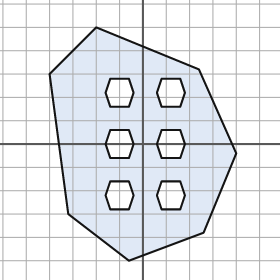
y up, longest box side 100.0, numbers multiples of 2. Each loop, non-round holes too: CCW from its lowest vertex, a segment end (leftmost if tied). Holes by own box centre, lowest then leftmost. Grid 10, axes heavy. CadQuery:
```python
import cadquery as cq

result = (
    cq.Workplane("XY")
    .moveTo(-6.0, -50.0)
    .lineTo(26.0, -38.0)
    .lineTo(40.0, -4.0)
    .lineTo(24.0, 32.0)
    .lineTo(-20.0, 50.0)
    .lineTo(-40.0, 30.0)
    .lineTo(-32.0, -30.0)
    .close()
    .moveTo(-14.0, -28.0)
    .lineTo(-6.0, -28.0)
    .lineTo(-4.0, -22.0)
    .lineTo(-6.0, -16.0)
    .lineTo(-14.0, -16.0)
    .lineTo(-16.0, -22.0)
    .close()
    .moveTo(8.0, -28.0)
    .lineTo(16.0, -28.0)
    .lineTo(18.0, -22.0)
    .lineTo(16.0, -16.0)
    .lineTo(8.0, -16.0)
    .lineTo(6.0, -22.0)
    .close()
    .moveTo(-14.0, -6.0)
    .lineTo(-6.0, -6.0)
    .lineTo(-4.0, 0.0)
    .lineTo(-6.0, 6.0)
    .lineTo(-14.0, 6.0)
    .lineTo(-16.0, 0.0)
    .close()
    .moveTo(8.0, -6.0)
    .lineTo(16.0, -6.0)
    .lineTo(18.0, 0.0)
    .lineTo(16.0, 6.0)
    .lineTo(8.0, 6.0)
    .lineTo(6.0, 0.0)
    .close()
    .moveTo(-14.0, 16.0)
    .lineTo(-6.0, 16.0)
    .lineTo(-4.0, 22.0)
    .lineTo(-6.0, 28.0)
    .lineTo(-14.0, 28.0)
    .lineTo(-16.0, 22.0)
    .close()
    .moveTo(8.0, 16.0)
    .lineTo(16.0, 16.0)
    .lineTo(18.0, 22.0)
    .lineTo(16.0, 28.0)
    .lineTo(8.0, 28.0)
    .lineTo(6.0, 22.0)
    .close()
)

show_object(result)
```